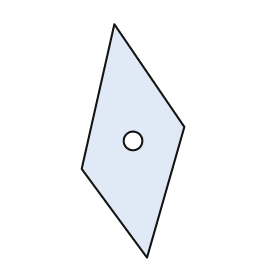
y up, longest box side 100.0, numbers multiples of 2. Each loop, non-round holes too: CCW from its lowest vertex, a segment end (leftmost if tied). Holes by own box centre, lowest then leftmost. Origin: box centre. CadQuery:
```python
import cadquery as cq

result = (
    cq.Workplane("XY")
    .moveTo(6.0, -50.0)
    .lineTo(22.0, 6.0)
    .lineTo(-8.0, 50.0)
    .lineTo(-22.0, -12.0)
    .close()
    .moveTo(0.0, 0.0)
    .circle(4.0)
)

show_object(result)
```